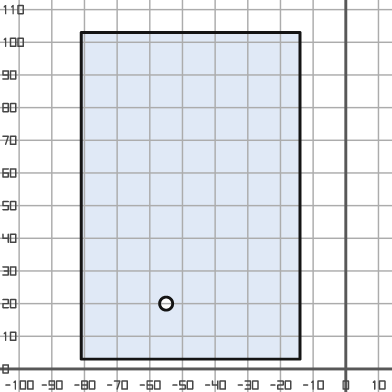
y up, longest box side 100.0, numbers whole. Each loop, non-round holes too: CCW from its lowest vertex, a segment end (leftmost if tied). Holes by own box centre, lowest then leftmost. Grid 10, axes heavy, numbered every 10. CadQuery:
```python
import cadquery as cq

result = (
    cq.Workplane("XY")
    .moveTo(-81.0, 3.0)
    .lineTo(-14.0, 3.0)
    .lineTo(-14.0, 103.0)
    .lineTo(-81.0, 103.0)
    .close()
    .moveTo(-55.0, 20.0)
    .circle(2.0)
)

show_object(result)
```